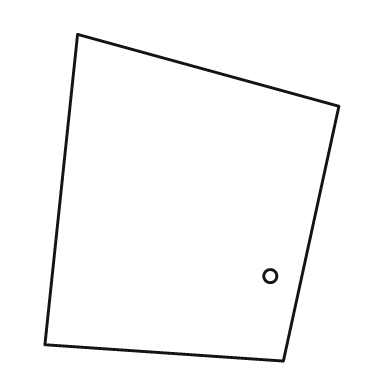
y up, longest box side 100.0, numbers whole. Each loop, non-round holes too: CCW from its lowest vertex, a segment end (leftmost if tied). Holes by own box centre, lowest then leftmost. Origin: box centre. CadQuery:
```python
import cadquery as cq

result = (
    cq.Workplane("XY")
    .moveTo(28.0, -50.0)
    .lineTo(45.0, 28.0)
    .lineTo(-35.0, 50.0)
    .lineTo(-45.0, -45.0)
    .close()
    .moveTo(24.0, -24.0)
    .circle(2.0)
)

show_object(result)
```